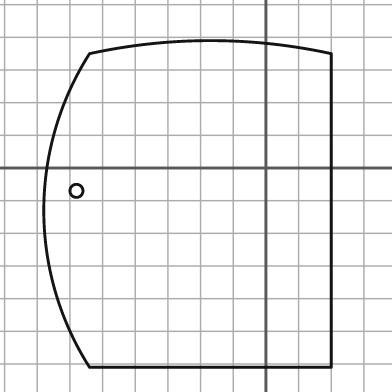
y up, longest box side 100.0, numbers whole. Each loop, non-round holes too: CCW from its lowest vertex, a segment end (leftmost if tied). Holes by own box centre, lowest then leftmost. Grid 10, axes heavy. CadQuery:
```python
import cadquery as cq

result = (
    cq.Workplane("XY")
    .moveTo(-54.0, -61.0)
    .lineTo(20.0, -61.0)
    .lineTo(20.0, 35.0)
    .threePointArc((-17.0, 39.0), (-54.0, 35.0))
    .threePointArc((-68.0, -13.0), (-54.0, -61.0))
    .close()
    .moveTo(-58.0, -7.0)
    .circle(2.0)
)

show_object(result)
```